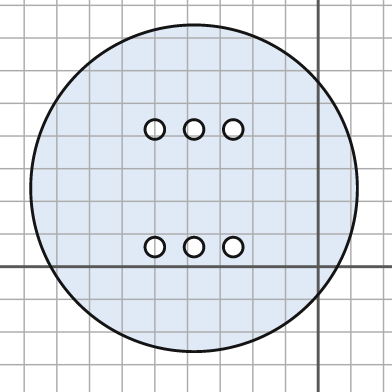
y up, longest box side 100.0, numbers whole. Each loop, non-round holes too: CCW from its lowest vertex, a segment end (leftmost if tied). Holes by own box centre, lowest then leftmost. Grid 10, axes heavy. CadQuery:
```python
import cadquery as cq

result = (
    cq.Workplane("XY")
    .moveTo(-38.0, 24.0)
    .circle(50.0)
    .moveTo(-50.0, 6.0)
    .circle(3.0)
    .moveTo(-38.0, 6.0)
    .circle(3.0)
    .moveTo(-26.0, 6.0)
    .circle(3.0)
    .moveTo(-50.0, 42.0)
    .circle(3.0)
    .moveTo(-38.0, 42.0)
    .circle(3.0)
    .moveTo(-26.0, 42.0)
    .circle(3.0)
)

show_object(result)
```